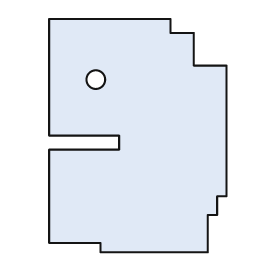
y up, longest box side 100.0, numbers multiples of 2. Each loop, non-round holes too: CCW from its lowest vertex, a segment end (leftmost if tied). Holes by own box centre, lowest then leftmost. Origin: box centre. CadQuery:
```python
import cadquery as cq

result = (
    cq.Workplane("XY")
    .moveTo(-16.0, -50.0)
    .lineTo(30.0, -50.0)
    .lineTo(30.0, -34.0)
    .lineTo(34.0, -34.0)
    .lineTo(34.0, -26.0)
    .lineTo(38.0, -26.0)
    .lineTo(38.0, 30.0)
    .lineTo(24.0, 30.0)
    .lineTo(24.0, 44.0)
    .lineTo(14.0, 44.0)
    .lineTo(14.0, 50.0)
    .lineTo(-38.0, 50.0)
    .lineTo(-38.0, 0.0)
    .lineTo(-8.0, 0.0)
    .lineTo(-8.0, -6.0)
    .lineTo(-38.0, -6.0)
    .lineTo(-38.0, -46.0)
    .lineTo(-16.0, -46.0)
    .close()
    .moveTo(-18.0, 24.0)
    .circle(4.0)
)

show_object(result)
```